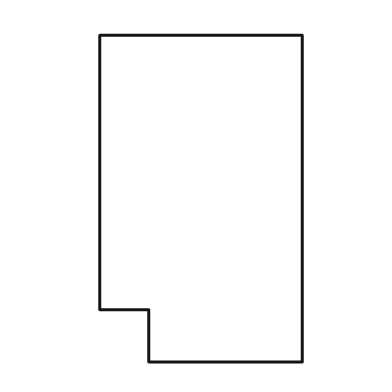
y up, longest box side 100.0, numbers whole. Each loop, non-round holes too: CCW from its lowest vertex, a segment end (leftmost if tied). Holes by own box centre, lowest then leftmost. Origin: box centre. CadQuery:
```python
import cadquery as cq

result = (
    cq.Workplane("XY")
    .moveTo(-16.0, -50.0)
    .lineTo(31.0, -50.0)
    .lineTo(31.0, 50.0)
    .lineTo(-31.0, 50.0)
    .lineTo(-31.0, -34.0)
    .lineTo(-16.0, -34.0)
    .close()
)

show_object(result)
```